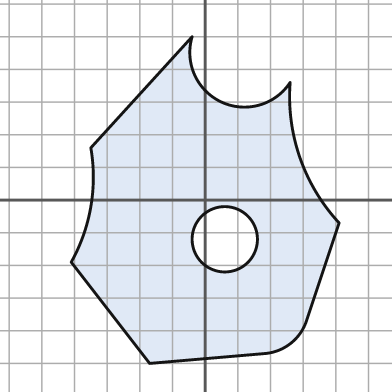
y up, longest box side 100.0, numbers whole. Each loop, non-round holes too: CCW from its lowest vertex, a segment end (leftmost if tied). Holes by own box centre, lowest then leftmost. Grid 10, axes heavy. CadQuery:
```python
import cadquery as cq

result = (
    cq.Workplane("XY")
    .moveTo(-17.0, -50.0)
    .lineTo(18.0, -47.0)
    .threePointArc((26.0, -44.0), (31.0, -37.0))
    .lineTo(41.0, -7.0)
    .threePointArc((29.0, 13.0), (26.0, 36.0))
    .threePointArc((5.0, 30.0), (-4.0, 50.0))
    .lineTo(-35.0, 16.0)
    .threePointArc((-35.0, -2.0), (-41.0, -19.0))
    .close()
    .moveTo(6.0, -12.0)
    .circle(10.0)
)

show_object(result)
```